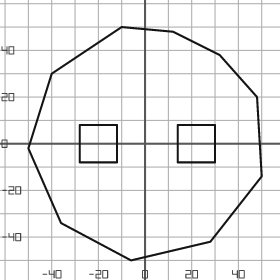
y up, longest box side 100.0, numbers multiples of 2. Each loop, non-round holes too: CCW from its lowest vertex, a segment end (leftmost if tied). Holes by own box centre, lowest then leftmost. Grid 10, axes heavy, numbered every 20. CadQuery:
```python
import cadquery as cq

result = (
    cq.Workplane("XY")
    .moveTo(-6.0, -50.0)
    .lineTo(28.0, -42.0)
    .lineTo(50.0, -14.0)
    .lineTo(48.0, 20.0)
    .lineTo(32.0, 38.0)
    .lineTo(12.0, 48.0)
    .lineTo(-10.0, 50.0)
    .lineTo(-40.0, 30.0)
    .lineTo(-50.0, -2.0)
    .lineTo(-36.0, -34.0)
    .close()
    .moveTo(-28.0, -8.0)
    .lineTo(-12.0, -8.0)
    .lineTo(-12.0, 8.0)
    .lineTo(-28.0, 8.0)
    .close()
    .moveTo(14.0, -8.0)
    .lineTo(30.0, -8.0)
    .lineTo(30.0, 8.0)
    .lineTo(14.0, 8.0)
    .close()
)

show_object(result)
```